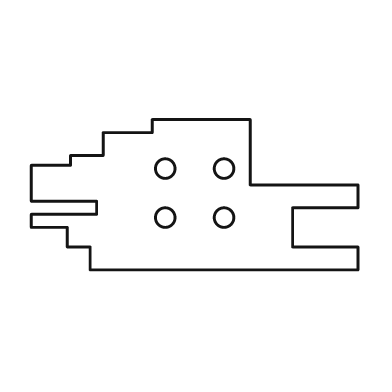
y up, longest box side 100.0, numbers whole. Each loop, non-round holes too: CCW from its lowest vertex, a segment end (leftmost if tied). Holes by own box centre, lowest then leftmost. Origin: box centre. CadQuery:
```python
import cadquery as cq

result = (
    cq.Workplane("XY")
    .moveTo(-32.0, -23.0)
    .lineTo(50.0, -23.0)
    .lineTo(50.0, -16.0)
    .lineTo(30.0, -16.0)
    .lineTo(30.0, -4.0)
    .lineTo(50.0, -4.0)
    .lineTo(50.0, 3.0)
    .lineTo(17.0, 3.0)
    .lineTo(17.0, 23.0)
    .lineTo(-13.0, 23.0)
    .lineTo(-13.0, 19.0)
    .lineTo(-28.0, 19.0)
    .lineTo(-28.0, 12.0)
    .lineTo(-38.0, 12.0)
    .lineTo(-38.0, 9.0)
    .lineTo(-50.0, 9.0)
    .lineTo(-50.0, -2.0)
    .lineTo(-30.0, -2.0)
    .lineTo(-30.0, -6.0)
    .lineTo(-50.0, -6.0)
    .lineTo(-50.0, -10.0)
    .lineTo(-39.0, -10.0)
    .lineTo(-39.0, -16.0)
    .lineTo(-32.0, -16.0)
    .close()
    .moveTo(-9.0, -7.0)
    .circle(3.0)
    .moveTo(9.0, -7.0)
    .circle(3.0)
    .moveTo(-9.0, 8.0)
    .circle(3.0)
    .moveTo(9.0, 8.0)
    .circle(3.0)
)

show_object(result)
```